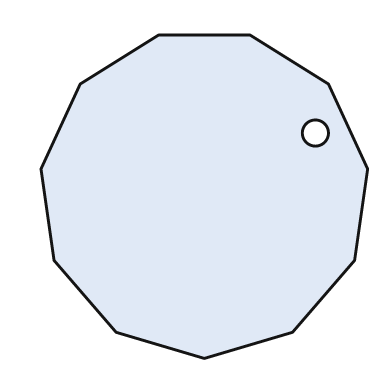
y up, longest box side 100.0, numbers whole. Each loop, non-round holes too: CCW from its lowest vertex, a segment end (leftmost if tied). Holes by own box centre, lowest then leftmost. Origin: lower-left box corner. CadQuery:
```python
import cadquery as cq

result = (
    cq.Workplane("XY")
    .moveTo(50.0, 0.0)
    .lineTo(77.0, 8.0)
    .lineTo(96.0, 30.0)
    .lineTo(100.0, 58.0)
    .lineTo(88.0, 84.0)
    .lineTo(64.0, 99.0)
    .lineTo(36.0, 99.0)
    .lineTo(12.0, 84.0)
    .lineTo(0.0, 58.0)
    .lineTo(4.0, 30.0)
    .lineTo(23.0, 8.0)
    .close()
    .moveTo(84.0, 69.0)
    .circle(4.0)
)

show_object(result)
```